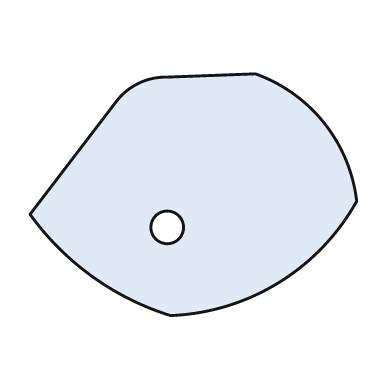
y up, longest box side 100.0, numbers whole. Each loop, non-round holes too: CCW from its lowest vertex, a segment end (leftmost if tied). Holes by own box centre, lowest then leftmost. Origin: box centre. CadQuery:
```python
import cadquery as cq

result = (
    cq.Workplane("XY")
    .moveTo(-7.0, -37.0)
    .threePointArc((26.0, -27.0), (50.0, -2.0))
    .threePointArc((40.0, 22.0), (19.0, 37.0))
    .lineTo(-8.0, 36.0)
    .threePointArc((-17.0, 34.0), (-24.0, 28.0))
    .lineTo(-50.0, -6.0)
    .threePointArc((-31.0, -25.0), (-7.0, -37.0))
    .close()
    .moveTo(-8.0, -10.0)
    .circle(5.0)
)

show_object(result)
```